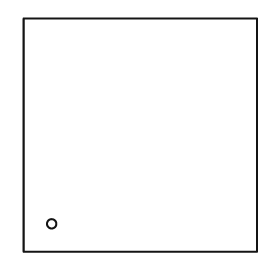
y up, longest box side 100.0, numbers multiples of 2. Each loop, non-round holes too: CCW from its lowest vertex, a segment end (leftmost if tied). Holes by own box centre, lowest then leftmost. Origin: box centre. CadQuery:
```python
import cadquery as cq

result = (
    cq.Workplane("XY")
    .moveTo(-50.0, -50.0)
    .lineTo(50.0, -50.0)
    .lineTo(50.0, 50.0)
    .lineTo(-50.0, 50.0)
    .close()
    .moveTo(-38.0, -38.0)
    .circle(2.0)
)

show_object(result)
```